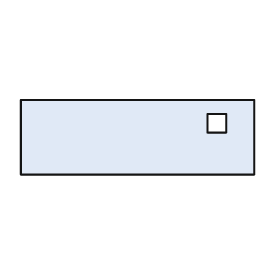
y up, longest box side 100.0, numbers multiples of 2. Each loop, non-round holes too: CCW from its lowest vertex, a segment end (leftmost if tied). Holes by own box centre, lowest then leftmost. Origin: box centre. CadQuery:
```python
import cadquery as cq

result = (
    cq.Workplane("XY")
    .moveTo(-50.0, -16.0)
    .lineTo(50.0, -16.0)
    .lineTo(50.0, 16.0)
    .lineTo(-50.0, 16.0)
    .close()
    .moveTo(30.0, 2.0)
    .lineTo(38.0, 2.0)
    .lineTo(38.0, 10.0)
    .lineTo(30.0, 10.0)
    .close()
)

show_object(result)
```